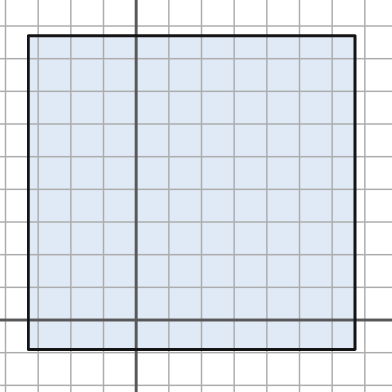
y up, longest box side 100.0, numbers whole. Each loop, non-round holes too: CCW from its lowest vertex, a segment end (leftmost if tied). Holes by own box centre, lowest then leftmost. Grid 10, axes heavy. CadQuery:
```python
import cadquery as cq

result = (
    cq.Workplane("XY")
    .moveTo(-33.0, -9.0)
    .lineTo(67.0, -9.0)
    .lineTo(67.0, 87.0)
    .lineTo(-33.0, 87.0)
    .close()
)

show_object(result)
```